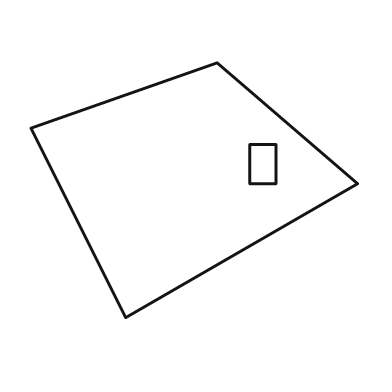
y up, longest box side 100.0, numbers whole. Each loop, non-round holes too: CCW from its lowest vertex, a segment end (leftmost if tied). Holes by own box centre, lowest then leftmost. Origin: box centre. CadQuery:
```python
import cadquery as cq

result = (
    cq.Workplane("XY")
    .moveTo(-21.0, -39.0)
    .lineTo(50.0, 2.0)
    .lineTo(7.0, 39.0)
    .lineTo(-50.0, 19.0)
    .close()
    .moveTo(17.0, 2.0)
    .lineTo(25.0, 2.0)
    .lineTo(25.0, 14.0)
    .lineTo(17.0, 14.0)
    .close()
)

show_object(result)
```